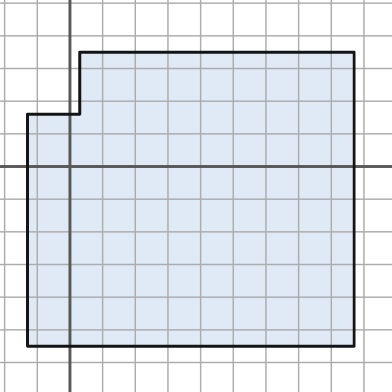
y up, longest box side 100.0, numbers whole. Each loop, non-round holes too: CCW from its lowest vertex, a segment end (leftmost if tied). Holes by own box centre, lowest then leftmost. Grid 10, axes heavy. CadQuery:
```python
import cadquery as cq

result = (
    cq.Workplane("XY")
    .moveTo(-13.0, -55.0)
    .lineTo(87.0, -55.0)
    .lineTo(87.0, 35.0)
    .lineTo(3.0, 35.0)
    .lineTo(3.0, 16.0)
    .lineTo(-13.0, 16.0)
    .close()
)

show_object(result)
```